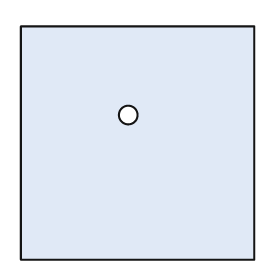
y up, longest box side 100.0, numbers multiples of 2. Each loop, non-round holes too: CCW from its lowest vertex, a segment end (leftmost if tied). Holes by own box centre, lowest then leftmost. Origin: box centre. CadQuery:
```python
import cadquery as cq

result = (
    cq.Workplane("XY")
    .moveTo(-50.0, -50.0)
    .lineTo(50.0, -50.0)
    .lineTo(50.0, 50.0)
    .lineTo(-50.0, 50.0)
    .close()
    .moveTo(-4.0, 12.0)
    .circle(4.0)
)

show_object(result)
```